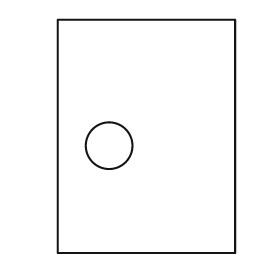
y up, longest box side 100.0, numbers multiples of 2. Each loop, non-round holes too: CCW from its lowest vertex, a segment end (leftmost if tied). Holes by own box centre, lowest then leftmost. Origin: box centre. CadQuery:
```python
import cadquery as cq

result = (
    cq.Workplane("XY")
    .moveTo(-38.0, -50.0)
    .lineTo(38.0, -50.0)
    .lineTo(38.0, 50.0)
    .lineTo(-38.0, 50.0)
    .close()
    .moveTo(-16.0, -4.0)
    .circle(10.0)
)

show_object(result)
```